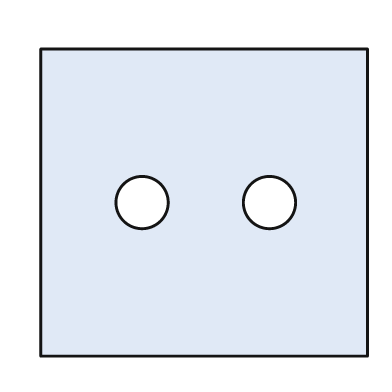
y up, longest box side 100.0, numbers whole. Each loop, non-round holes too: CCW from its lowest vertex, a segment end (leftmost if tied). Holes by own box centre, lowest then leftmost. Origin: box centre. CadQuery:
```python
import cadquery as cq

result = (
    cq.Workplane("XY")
    .moveTo(-50.0, -47.0)
    .lineTo(50.0, -47.0)
    .lineTo(50.0, 47.0)
    .lineTo(-50.0, 47.0)
    .close()
    .moveTo(-19.0, 0.0)
    .circle(8.0)
    .moveTo(20.0, 0.0)
    .circle(8.0)
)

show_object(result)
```